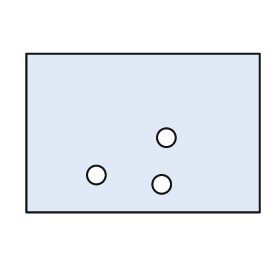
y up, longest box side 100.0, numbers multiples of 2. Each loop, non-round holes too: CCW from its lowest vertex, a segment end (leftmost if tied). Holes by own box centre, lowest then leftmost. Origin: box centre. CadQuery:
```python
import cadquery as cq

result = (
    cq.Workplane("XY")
    .moveTo(-50.0, -34.0)
    .lineTo(50.0, -34.0)
    .lineTo(50.0, 34.0)
    .lineTo(-50.0, 34.0)
    .close()
    .moveTo(8.0, -22.0)
    .circle(4.0)
    .moveTo(-20.0, -18.0)
    .circle(4.0)
    .moveTo(10.0, -2.0)
    .circle(4.0)
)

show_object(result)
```